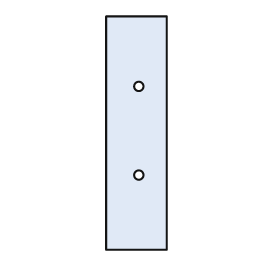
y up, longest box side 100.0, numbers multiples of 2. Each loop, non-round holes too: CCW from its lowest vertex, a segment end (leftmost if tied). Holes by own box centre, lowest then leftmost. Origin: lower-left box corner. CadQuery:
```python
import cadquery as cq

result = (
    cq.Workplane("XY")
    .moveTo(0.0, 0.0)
    .lineTo(26.0, 0.0)
    .lineTo(26.0, 100.0)
    .lineTo(0.0, 100.0)
    .close()
    .moveTo(14.0, 32.0)
    .circle(2.0)
    .moveTo(14.0, 70.0)
    .circle(2.0)
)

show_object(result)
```